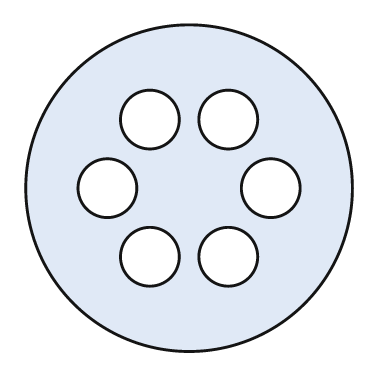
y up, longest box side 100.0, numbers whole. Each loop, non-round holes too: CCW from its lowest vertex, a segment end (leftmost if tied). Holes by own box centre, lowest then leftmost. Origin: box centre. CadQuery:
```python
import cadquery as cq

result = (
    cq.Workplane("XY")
    .moveTo(0.0, 0.0)
    .circle(50.0)
    .moveTo(-12.0, -21.0)
    .circle(9.0)
    .moveTo(12.0, -21.0)
    .circle(9.0)
    .moveTo(-25.0, 0.0)
    .circle(9.0)
    .moveTo(25.0, 0.0)
    .circle(9.0)
    .moveTo(-12.0, 21.0)
    .circle(9.0)
    .moveTo(12.0, 21.0)
    .circle(9.0)
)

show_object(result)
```